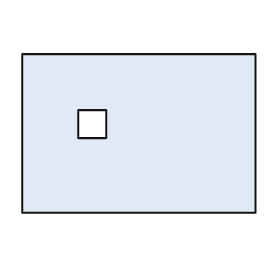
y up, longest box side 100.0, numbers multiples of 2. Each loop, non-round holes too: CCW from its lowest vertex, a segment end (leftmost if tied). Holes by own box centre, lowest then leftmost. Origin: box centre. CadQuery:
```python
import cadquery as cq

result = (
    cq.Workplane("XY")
    .moveTo(-50.0, -34.0)
    .lineTo(50.0, -34.0)
    .lineTo(50.0, 34.0)
    .lineTo(-50.0, 34.0)
    .close()
    .moveTo(-26.0, -2.0)
    .lineTo(-14.0, -2.0)
    .lineTo(-14.0, 10.0)
    .lineTo(-26.0, 10.0)
    .close()
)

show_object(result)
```